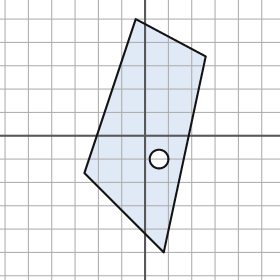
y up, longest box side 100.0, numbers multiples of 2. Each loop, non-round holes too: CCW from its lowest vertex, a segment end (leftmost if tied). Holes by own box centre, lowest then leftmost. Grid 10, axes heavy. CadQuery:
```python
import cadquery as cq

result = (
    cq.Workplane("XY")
    .moveTo(8.0, -50.0)
    .lineTo(26.0, 34.0)
    .lineTo(-4.0, 50.0)
    .lineTo(-26.0, -16.0)
    .close()
    .moveTo(6.0, -10.0)
    .circle(4.0)
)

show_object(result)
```